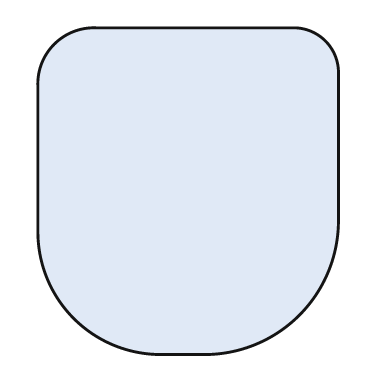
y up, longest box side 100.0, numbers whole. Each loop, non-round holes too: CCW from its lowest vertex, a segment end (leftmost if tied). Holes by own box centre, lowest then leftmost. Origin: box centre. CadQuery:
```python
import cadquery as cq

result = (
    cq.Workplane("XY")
    .moveTo(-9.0, -50.0)
    .lineTo(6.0, -50.0)
    .threePointArc((34.0, -38.0), (46.0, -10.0))
    .lineTo(46.0, 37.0)
    .threePointArc((42.0, 46.0), (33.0, 50.0))
    .lineTo(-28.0, 50.0)
    .threePointArc((-41.0, 45.0), (-46.0, 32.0))
    .lineTo(-46.0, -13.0)
    .threePointArc((-35.0, -39.0), (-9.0, -50.0))
    .close()
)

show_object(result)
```